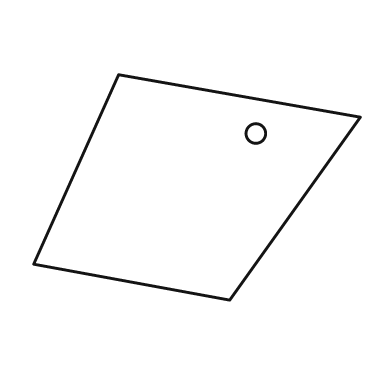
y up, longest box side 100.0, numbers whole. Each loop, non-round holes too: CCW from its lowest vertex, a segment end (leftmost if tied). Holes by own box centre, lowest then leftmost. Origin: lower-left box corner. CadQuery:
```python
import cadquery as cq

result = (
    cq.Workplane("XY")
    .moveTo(60.0, 0.0)
    .lineTo(100.0, 56.0)
    .lineTo(26.0, 69.0)
    .lineTo(0.0, 11.0)
    .close()
    .moveTo(68.0, 51.0)
    .circle(3.0)
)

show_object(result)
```